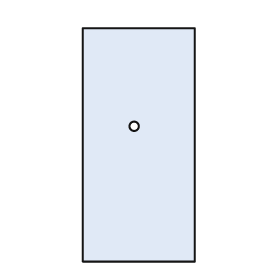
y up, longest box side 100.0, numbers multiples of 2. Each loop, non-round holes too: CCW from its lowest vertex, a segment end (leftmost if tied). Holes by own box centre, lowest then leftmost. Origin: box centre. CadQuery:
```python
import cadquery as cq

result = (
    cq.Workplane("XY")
    .moveTo(-24.0, -50.0)
    .lineTo(24.0, -50.0)
    .lineTo(24.0, 50.0)
    .lineTo(-24.0, 50.0)
    .close()
    .moveTo(-2.0, 8.0)
    .circle(2.0)
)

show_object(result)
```